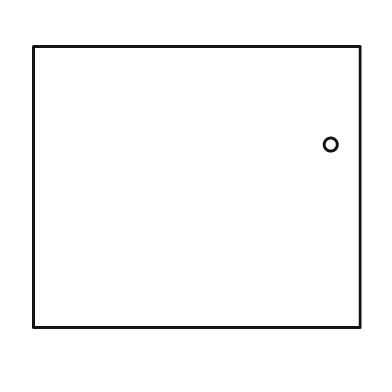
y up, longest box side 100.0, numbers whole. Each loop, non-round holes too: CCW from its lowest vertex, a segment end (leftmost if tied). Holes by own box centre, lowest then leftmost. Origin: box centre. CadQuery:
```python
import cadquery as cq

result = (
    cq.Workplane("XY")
    .moveTo(-50.0, -43.0)
    .lineTo(50.0, -43.0)
    .lineTo(50.0, 43.0)
    .lineTo(-50.0, 43.0)
    .close()
    .moveTo(41.0, 13.0)
    .circle(2.0)
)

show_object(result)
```